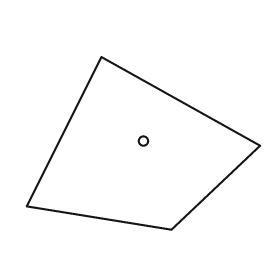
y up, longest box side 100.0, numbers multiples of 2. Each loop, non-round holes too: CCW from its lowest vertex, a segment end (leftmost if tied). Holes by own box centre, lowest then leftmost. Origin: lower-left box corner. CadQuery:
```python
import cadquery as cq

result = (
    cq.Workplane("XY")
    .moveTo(62.0, 0.0)
    .lineTo(100.0, 36.0)
    .lineTo(32.0, 74.0)
    .lineTo(0.0, 10.0)
    .close()
    .moveTo(50.0, 38.0)
    .circle(2.0)
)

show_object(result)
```